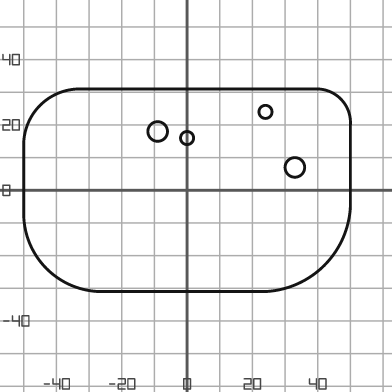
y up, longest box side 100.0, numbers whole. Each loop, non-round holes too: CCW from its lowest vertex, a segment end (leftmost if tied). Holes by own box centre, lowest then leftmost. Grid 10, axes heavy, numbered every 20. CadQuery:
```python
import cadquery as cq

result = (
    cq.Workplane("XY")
    .moveTo(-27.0, -31.0)
    .lineTo(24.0, -31.0)
    .threePointArc((42.0, -23.0), (50.0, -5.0))
    .lineTo(50.0, 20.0)
    .threePointArc((47.0, 28.0), (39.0, 31.0))
    .lineTo(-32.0, 31.0)
    .threePointArc((-45.0, 26.0), (-50.0, 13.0))
    .lineTo(-50.0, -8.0)
    .threePointArc((-43.0, -24.0), (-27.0, -31.0))
    .close()
    .moveTo(33.0, 7.0)
    .circle(3.0)
    .moveTo(0.0, 16.0)
    .circle(2.0)
    .moveTo(-9.0, 18.0)
    .circle(3.0)
    .moveTo(24.0, 24.0)
    .circle(2.0)
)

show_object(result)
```